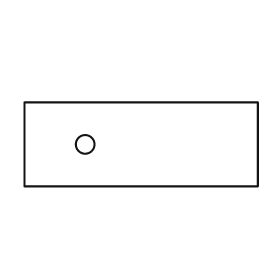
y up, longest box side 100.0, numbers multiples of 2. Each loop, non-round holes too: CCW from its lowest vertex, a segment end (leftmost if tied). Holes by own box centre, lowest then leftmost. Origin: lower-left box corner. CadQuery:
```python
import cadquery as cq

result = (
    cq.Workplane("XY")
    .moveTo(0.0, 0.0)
    .lineTo(100.0, 0.0)
    .lineTo(100.0, 36.0)
    .lineTo(0.0, 36.0)
    .close()
    .moveTo(26.0, 18.0)
    .circle(4.0)
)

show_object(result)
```